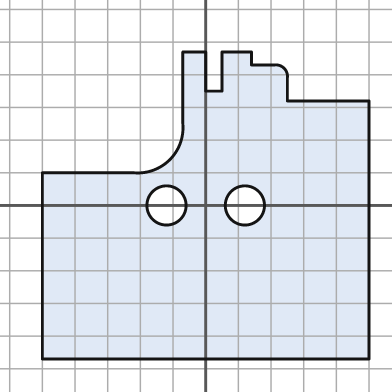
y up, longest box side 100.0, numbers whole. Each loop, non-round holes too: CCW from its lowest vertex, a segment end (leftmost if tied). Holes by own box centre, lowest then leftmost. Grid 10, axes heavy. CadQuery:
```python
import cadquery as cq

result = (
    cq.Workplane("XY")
    .moveTo(-50.0, -47.0)
    .lineTo(50.0, -47.0)
    .lineTo(50.0, 32.0)
    .lineTo(25.0, 32.0)
    .lineTo(25.0, 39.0)
    .threePointArc((24.0, 42.0), (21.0, 43.0))
    .lineTo(14.0, 43.0)
    .lineTo(14.0, 47.0)
    .lineTo(5.0, 47.0)
    .lineTo(5.0, 35.0)
    .lineTo(0.0, 35.0)
    .lineTo(0.0, 47.0)
    .lineTo(-7.0, 47.0)
    .lineTo(-7.0, 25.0)
    .threePointArc((-11.0, 14.0), (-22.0, 10.0))
    .lineTo(-50.0, 10.0)
    .close()
    .moveTo(-12.0, 0.0)
    .circle(6.0)
    .moveTo(12.0, 0.0)
    .circle(6.0)
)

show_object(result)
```